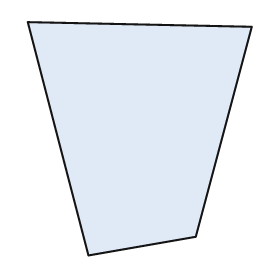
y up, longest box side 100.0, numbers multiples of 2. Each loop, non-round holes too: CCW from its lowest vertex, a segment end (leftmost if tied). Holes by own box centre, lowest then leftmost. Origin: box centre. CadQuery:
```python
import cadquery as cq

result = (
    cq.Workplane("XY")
    .moveTo(-22.0, -50.0)
    .lineTo(24.0, -42.0)
    .lineTo(48.0, 48.0)
    .lineTo(-48.0, 50.0)
    .close()
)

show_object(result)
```